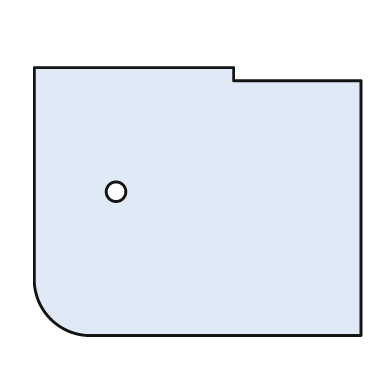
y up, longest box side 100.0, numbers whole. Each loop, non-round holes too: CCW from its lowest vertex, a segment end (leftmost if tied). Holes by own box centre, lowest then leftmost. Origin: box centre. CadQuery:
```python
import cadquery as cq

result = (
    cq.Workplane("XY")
    .moveTo(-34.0, -41.0)
    .lineTo(50.0, -41.0)
    .lineTo(50.0, 37.0)
    .lineTo(11.0, 37.0)
    .lineTo(11.0, 41.0)
    .lineTo(-50.0, 41.0)
    .lineTo(-50.0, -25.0)
    .threePointArc((-45.0, -36.0), (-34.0, -41.0))
    .close()
    .moveTo(-25.0, 3.0)
    .circle(3.0)
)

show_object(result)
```